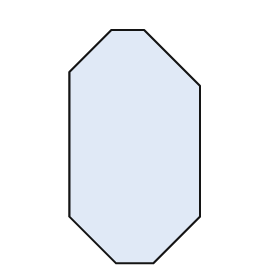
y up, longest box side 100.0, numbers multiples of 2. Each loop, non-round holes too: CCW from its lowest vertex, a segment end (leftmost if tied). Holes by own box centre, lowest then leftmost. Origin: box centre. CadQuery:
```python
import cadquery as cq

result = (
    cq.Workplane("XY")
    .moveTo(-8.0, -50.0)
    .lineTo(8.0, -50.0)
    .lineTo(28.0, -30.0)
    .lineTo(28.0, 26.0)
    .lineTo(4.0, 50.0)
    .lineTo(-10.0, 50.0)
    .lineTo(-28.0, 32.0)
    .lineTo(-28.0, -30.0)
    .close()
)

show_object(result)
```